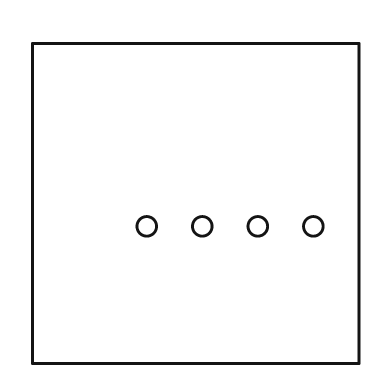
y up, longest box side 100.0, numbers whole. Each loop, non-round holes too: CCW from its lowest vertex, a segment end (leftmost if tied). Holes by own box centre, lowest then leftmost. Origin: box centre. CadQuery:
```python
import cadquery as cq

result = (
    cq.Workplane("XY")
    .moveTo(-50.0, -49.0)
    .lineTo(50.0, -49.0)
    .lineTo(50.0, 49.0)
    .lineTo(-50.0, 49.0)
    .close()
    .moveTo(-15.0, -7.0)
    .circle(3.0)
    .moveTo(2.0, -7.0)
    .circle(3.0)
    .moveTo(19.0, -7.0)
    .circle(3.0)
    .moveTo(36.0, -7.0)
    .circle(3.0)
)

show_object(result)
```